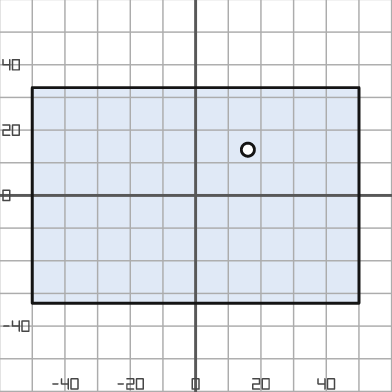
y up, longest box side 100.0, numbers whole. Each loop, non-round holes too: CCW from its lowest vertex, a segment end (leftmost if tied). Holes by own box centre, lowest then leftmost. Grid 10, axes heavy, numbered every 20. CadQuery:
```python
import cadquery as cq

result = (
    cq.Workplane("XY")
    .moveTo(-50.0, -33.0)
    .lineTo(50.0, -33.0)
    .lineTo(50.0, 33.0)
    .lineTo(-50.0, 33.0)
    .close()
    .moveTo(16.0, 14.0)
    .circle(2.0)
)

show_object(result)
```